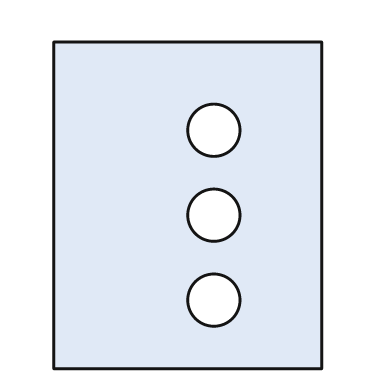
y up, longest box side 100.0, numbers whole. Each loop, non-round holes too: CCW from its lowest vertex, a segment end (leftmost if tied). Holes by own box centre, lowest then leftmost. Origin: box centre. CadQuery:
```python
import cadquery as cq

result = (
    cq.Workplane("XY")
    .moveTo(-41.0, -50.0)
    .lineTo(41.0, -50.0)
    .lineTo(41.0, 50.0)
    .lineTo(-41.0, 50.0)
    .close()
    .moveTo(8.0, -29.0)
    .circle(8.0)
    .moveTo(8.0, -3.0)
    .circle(8.0)
    .moveTo(8.0, 23.0)
    .circle(8.0)
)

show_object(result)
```